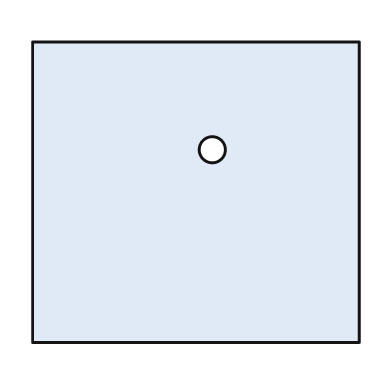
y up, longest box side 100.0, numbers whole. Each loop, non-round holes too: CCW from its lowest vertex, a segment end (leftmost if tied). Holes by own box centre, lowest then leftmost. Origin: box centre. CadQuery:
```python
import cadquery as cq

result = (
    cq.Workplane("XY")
    .moveTo(-50.0, -46.0)
    .lineTo(50.0, -46.0)
    .lineTo(50.0, 46.0)
    .lineTo(-50.0, 46.0)
    .close()
    .moveTo(5.0, 13.0)
    .circle(4.0)
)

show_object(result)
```